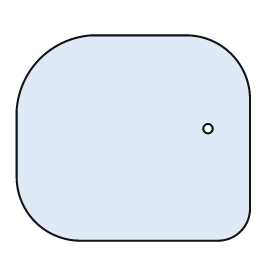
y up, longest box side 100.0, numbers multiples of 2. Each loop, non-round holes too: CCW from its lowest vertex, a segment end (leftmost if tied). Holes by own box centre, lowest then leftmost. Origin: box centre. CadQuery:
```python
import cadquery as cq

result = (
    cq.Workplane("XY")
    .moveTo(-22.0, -44.0)
    .lineTo(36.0, -44.0)
    .threePointArc((46.0, -40.0), (50.0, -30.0))
    .lineTo(50.0, 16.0)
    .threePointArc((42.0, 36.0), (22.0, 44.0))
    .lineTo(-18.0, 44.0)
    .threePointArc((-40.0, 34.0), (-50.0, 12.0))
    .lineTo(-50.0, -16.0)
    .threePointArc((-42.0, -36.0), (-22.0, -44.0))
    .close()
    .moveTo(32.0, 4.0)
    .circle(2.0)
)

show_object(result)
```